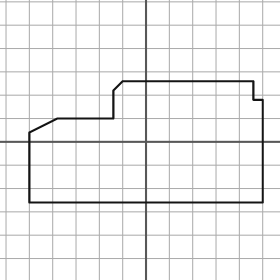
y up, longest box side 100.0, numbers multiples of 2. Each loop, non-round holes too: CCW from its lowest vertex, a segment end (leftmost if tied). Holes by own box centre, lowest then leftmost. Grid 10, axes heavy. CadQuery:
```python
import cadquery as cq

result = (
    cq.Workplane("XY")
    .moveTo(-50.0, -26.0)
    .lineTo(50.0, -26.0)
    .lineTo(50.0, 18.0)
    .lineTo(46.0, 18.0)
    .lineTo(46.0, 26.0)
    .lineTo(-10.0, 26.0)
    .lineTo(-14.0, 22.0)
    .lineTo(-14.0, 10.0)
    .lineTo(-38.0, 10.0)
    .lineTo(-50.0, 4.0)
    .close()
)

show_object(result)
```